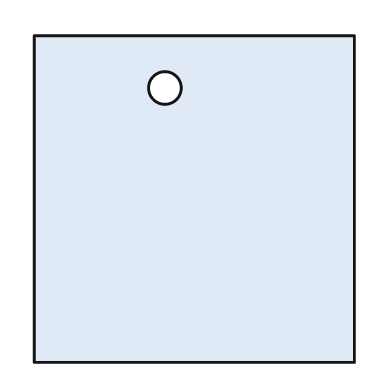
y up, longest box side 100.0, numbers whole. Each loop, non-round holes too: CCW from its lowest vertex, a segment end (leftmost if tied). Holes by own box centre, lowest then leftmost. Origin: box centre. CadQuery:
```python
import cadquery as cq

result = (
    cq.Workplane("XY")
    .moveTo(-49.0, -50.0)
    .lineTo(49.0, -50.0)
    .lineTo(49.0, 50.0)
    .lineTo(-49.0, 50.0)
    .close()
    .moveTo(-9.0, 34.0)
    .circle(5.0)
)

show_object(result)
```